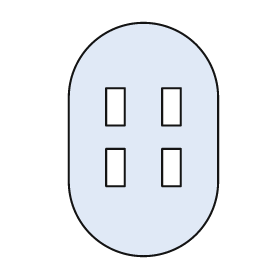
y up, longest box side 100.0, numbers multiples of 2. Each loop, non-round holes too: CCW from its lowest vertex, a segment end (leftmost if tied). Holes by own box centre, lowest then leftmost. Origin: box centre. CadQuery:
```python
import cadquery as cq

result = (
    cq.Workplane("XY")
    .moveTo(-32.0, -18.0)
    .threePointArc((0.0, -50.0), (32.0, -18.0))
    .lineTo(32.0, 18.0)
    .threePointArc((0.0, 50.0), (-32.0, 18.0))
    .close()
    .moveTo(-16.0, -20.0)
    .lineTo(-8.0, -20.0)
    .lineTo(-8.0, -4.0)
    .lineTo(-16.0, -4.0)
    .close()
    .moveTo(8.0, -20.0)
    .lineTo(16.0, -20.0)
    .lineTo(16.0, -4.0)
    .lineTo(8.0, -4.0)
    .close()
    .moveTo(-16.0, 6.0)
    .lineTo(-8.0, 6.0)
    .lineTo(-8.0, 22.0)
    .lineTo(-16.0, 22.0)
    .close()
    .moveTo(8.0, 6.0)
    .lineTo(16.0, 6.0)
    .lineTo(16.0, 22.0)
    .lineTo(8.0, 22.0)
    .close()
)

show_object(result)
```